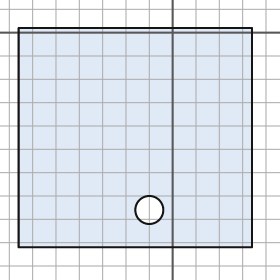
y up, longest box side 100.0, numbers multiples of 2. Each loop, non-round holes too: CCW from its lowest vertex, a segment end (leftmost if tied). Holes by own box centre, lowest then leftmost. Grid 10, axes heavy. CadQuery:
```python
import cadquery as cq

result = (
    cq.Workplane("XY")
    .moveTo(-66.0, -92.0)
    .lineTo(34.0, -92.0)
    .lineTo(34.0, 2.0)
    .lineTo(-66.0, 2.0)
    .close()
    .moveTo(-10.0, -76.0)
    .circle(6.0)
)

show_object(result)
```